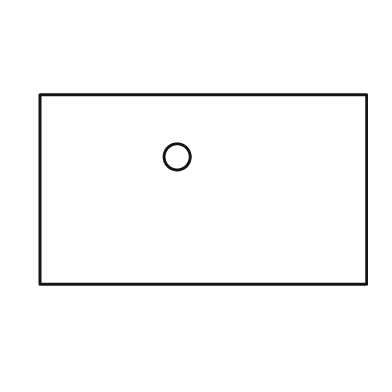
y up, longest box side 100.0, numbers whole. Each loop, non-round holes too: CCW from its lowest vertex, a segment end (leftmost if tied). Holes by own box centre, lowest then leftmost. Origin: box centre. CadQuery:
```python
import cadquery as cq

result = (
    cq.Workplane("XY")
    .moveTo(-50.0, -29.0)
    .lineTo(50.0, -29.0)
    .lineTo(50.0, 29.0)
    .lineTo(-50.0, 29.0)
    .close()
    .moveTo(-8.0, 10.0)
    .circle(4.0)
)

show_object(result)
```